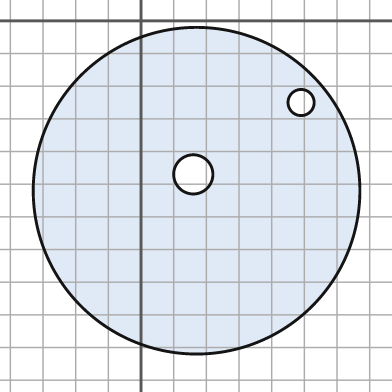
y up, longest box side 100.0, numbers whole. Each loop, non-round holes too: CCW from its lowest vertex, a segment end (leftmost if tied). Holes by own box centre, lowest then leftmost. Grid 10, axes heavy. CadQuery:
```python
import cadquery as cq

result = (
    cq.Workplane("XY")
    .moveTo(17.0, -52.0)
    .circle(50.0)
    .moveTo(16.0, -47.0)
    .circle(6.0)
    .moveTo(49.0, -25.0)
    .circle(4.0)
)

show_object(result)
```